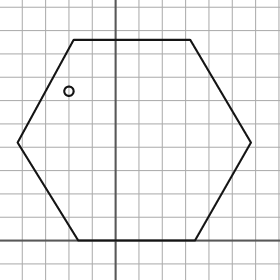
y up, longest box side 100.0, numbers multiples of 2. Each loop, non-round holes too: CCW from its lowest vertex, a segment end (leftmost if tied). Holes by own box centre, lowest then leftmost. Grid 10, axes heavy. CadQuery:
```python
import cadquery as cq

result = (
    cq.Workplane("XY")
    .moveTo(-16.0, 0.0)
    .lineTo(34.0, 0.0)
    .lineTo(58.0, 42.0)
    .lineTo(32.0, 86.0)
    .lineTo(-18.0, 86.0)
    .lineTo(-42.0, 42.0)
    .close()
    .moveTo(-20.0, 64.0)
    .circle(2.0)
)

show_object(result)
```